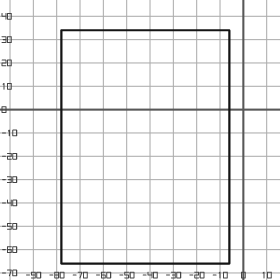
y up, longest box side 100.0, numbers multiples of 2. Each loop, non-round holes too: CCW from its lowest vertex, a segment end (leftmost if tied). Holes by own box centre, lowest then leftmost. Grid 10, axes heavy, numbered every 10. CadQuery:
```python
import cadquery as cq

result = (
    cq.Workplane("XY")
    .moveTo(-78.0, -66.0)
    .lineTo(-6.0, -66.0)
    .lineTo(-6.0, 34.0)
    .lineTo(-78.0, 34.0)
    .close()
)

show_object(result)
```